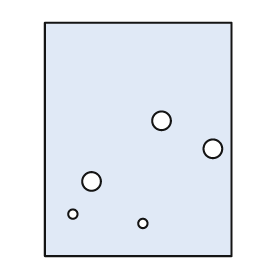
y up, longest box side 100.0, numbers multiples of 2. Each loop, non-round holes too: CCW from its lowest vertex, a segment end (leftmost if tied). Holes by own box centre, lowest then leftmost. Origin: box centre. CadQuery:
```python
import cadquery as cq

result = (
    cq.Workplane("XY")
    .moveTo(-40.0, -50.0)
    .lineTo(40.0, -50.0)
    .lineTo(40.0, 50.0)
    .lineTo(-40.0, 50.0)
    .close()
    .moveTo(2.0, -36.0)
    .circle(2.0)
    .moveTo(-28.0, -32.0)
    .circle(2.0)
    .moveTo(-20.0, -18.0)
    .circle(4.0)
    .moveTo(32.0, -4.0)
    .circle(4.0)
    .moveTo(10.0, 8.0)
    .circle(4.0)
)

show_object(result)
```